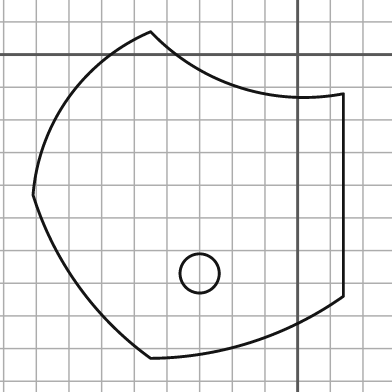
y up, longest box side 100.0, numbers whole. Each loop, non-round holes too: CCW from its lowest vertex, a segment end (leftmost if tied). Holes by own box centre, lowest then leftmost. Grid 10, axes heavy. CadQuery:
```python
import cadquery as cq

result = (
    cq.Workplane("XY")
    .moveTo(-45.0, -93.0)
    .threePointArc((-14.0, -88.0), (14.0, -74.0))
    .lineTo(14.0, -12.0)
    .threePointArc((-18.0, -10.0), (-45.0, 7.0))
    .threePointArc((-70.0, -13.0), (-81.0, -43.0))
    .threePointArc((-67.0, -71.0), (-45.0, -93.0))
    .close()
    .moveTo(-30.0, -67.0)
    .circle(6.0)
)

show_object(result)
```